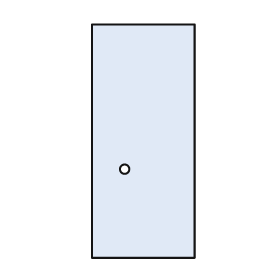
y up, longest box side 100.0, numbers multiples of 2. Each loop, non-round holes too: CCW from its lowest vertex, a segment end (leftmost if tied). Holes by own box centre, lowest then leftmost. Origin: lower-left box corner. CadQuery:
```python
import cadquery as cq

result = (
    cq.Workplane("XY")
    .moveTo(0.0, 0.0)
    .lineTo(44.0, 0.0)
    .lineTo(44.0, 100.0)
    .lineTo(0.0, 100.0)
    .close()
    .moveTo(14.0, 38.0)
    .circle(2.0)
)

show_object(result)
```